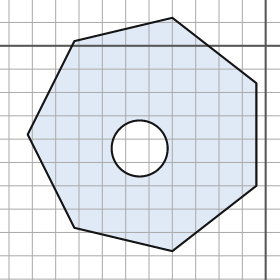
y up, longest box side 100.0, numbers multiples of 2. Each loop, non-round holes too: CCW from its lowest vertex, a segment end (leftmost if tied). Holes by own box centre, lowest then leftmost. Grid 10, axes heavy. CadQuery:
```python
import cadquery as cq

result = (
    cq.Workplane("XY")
    .moveTo(-40.0, -88.0)
    .lineTo(-4.0, -60.0)
    .lineTo(-4.0, -16.0)
    .lineTo(-40.0, 12.0)
    .lineTo(-82.0, 2.0)
    .lineTo(-102.0, -38.0)
    .lineTo(-82.0, -78.0)
    .close()
    .moveTo(-54.0, -44.0)
    .circle(12.0)
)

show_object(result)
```